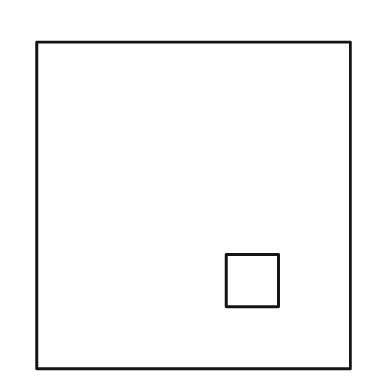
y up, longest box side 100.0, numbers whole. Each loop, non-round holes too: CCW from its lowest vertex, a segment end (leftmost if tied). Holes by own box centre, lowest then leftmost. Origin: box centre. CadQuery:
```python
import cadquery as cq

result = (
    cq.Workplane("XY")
    .moveTo(-48.0, -50.0)
    .lineTo(48.0, -50.0)
    .lineTo(48.0, 50.0)
    .lineTo(-48.0, 50.0)
    .close()
    .moveTo(10.0, -31.0)
    .lineTo(26.0, -31.0)
    .lineTo(26.0, -15.0)
    .lineTo(10.0, -15.0)
    .close()
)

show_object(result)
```